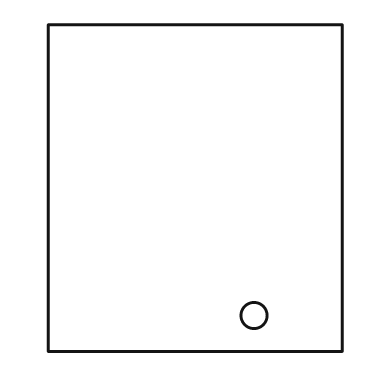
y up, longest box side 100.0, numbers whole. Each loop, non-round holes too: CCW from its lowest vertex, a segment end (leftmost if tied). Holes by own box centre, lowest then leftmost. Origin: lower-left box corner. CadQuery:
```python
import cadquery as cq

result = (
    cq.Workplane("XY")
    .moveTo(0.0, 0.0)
    .lineTo(90.0, 0.0)
    .lineTo(90.0, 100.0)
    .lineTo(0.0, 100.0)
    .close()
    .moveTo(63.0, 11.0)
    .circle(4.0)
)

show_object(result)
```